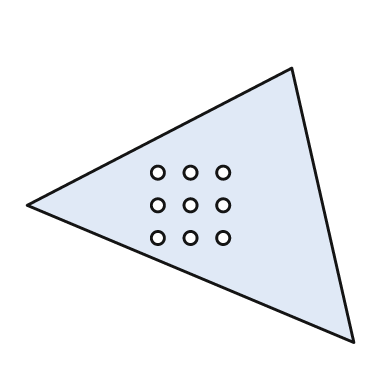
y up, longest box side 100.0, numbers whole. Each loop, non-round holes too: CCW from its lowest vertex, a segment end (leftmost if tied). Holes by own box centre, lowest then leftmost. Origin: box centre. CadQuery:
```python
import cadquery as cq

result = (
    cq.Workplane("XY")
    .moveTo(50.0, -42.0)
    .lineTo(31.0, 42.0)
    .lineTo(-50.0, 0.0)
    .close()
    .moveTo(-10.0, -10.0)
    .circle(2.0)
    .moveTo(0.0, -10.0)
    .circle(2.0)
    .moveTo(10.0, -10.0)
    .circle(2.0)
    .moveTo(-10.0, 0.0)
    .circle(2.0)
    .moveTo(0.0, 0.0)
    .circle(2.0)
    .moveTo(10.0, 0.0)
    .circle(2.0)
    .moveTo(-10.0, 10.0)
    .circle(2.0)
    .moveTo(0.0, 10.0)
    .circle(2.0)
    .moveTo(10.0, 10.0)
    .circle(2.0)
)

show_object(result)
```